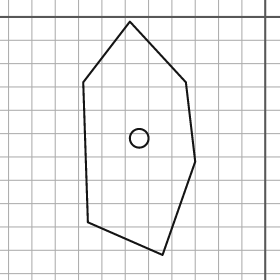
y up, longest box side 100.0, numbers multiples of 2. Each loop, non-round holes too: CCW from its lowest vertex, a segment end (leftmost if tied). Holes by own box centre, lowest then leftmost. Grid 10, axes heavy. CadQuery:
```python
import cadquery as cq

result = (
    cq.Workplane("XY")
    .moveTo(-44.0, -102.0)
    .lineTo(-30.0, -62.0)
    .lineTo(-34.0, -28.0)
    .lineTo(-58.0, -2.0)
    .lineTo(-78.0, -28.0)
    .lineTo(-76.0, -88.0)
    .close()
    .moveTo(-54.0, -52.0)
    .circle(4.0)
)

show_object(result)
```